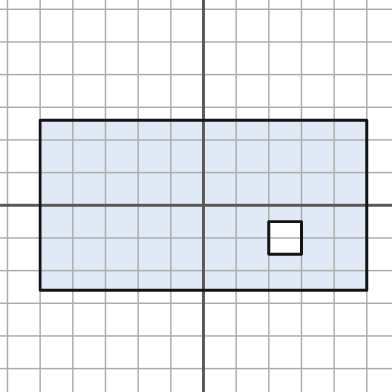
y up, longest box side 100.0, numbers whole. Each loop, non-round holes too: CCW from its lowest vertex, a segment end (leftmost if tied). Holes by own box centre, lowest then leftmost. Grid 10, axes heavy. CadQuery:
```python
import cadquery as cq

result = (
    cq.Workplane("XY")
    .moveTo(-50.0, -26.0)
    .lineTo(50.0, -26.0)
    .lineTo(50.0, 26.0)
    .lineTo(-50.0, 26.0)
    .close()
    .moveTo(20.0, -15.0)
    .lineTo(30.0, -15.0)
    .lineTo(30.0, -5.0)
    .lineTo(20.0, -5.0)
    .close()
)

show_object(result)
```